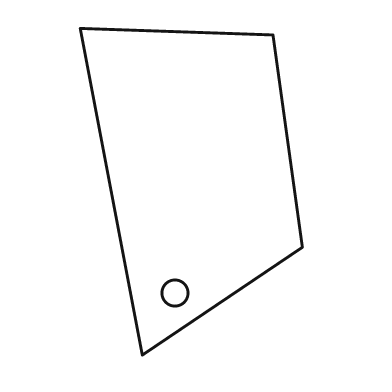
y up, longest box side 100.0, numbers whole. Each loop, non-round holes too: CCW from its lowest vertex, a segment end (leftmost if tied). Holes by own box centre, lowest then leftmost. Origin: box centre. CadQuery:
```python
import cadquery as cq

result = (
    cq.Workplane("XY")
    .moveTo(-15.0, -50.0)
    .lineTo(34.0, -17.0)
    .lineTo(25.0, 48.0)
    .lineTo(-34.0, 50.0)
    .close()
    .moveTo(-5.0, -31.0)
    .circle(4.0)
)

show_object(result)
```